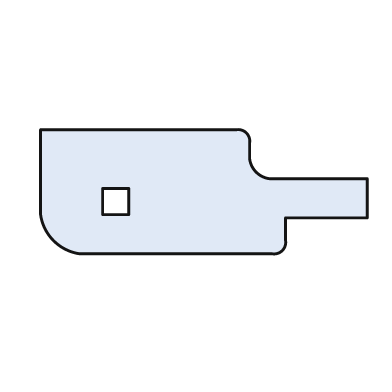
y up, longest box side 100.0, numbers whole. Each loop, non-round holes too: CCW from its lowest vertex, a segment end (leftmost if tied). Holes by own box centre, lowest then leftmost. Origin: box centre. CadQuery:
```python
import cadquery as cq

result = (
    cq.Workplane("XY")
    .moveTo(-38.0, -19.0)
    .lineTo(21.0, -19.0)
    .threePointArc((24.0, -18.0), (25.0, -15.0))
    .lineTo(25.0, -8.0)
    .lineTo(50.0, -8.0)
    .lineTo(50.0, 4.0)
    .lineTo(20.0, 4.0)
    .threePointArc((16.0, 6.0), (14.0, 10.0))
    .lineTo(14.0, 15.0)
    .threePointArc((13.0, 18.0), (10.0, 19.0))
    .lineTo(-50.0, 19.0)
    .lineTo(-50.0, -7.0)
    .threePointArc((-46.0, -15.0), (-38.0, -19.0))
    .close()
    .moveTo(-31.0, -7.0)
    .lineTo(-23.0, -7.0)
    .lineTo(-23.0, 1.0)
    .lineTo(-31.0, 1.0)
    .close()
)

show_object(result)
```